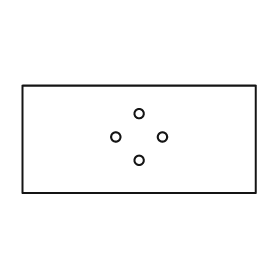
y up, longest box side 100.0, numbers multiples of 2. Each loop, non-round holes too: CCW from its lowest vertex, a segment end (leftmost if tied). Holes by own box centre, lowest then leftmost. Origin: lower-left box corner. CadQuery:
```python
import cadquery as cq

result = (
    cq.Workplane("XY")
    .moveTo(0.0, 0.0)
    .lineTo(100.0, 0.0)
    .lineTo(100.0, 46.0)
    .lineTo(0.0, 46.0)
    .close()
    .moveTo(50.0, 14.0)
    .circle(2.0)
    .moveTo(40.0, 24.0)
    .circle(2.0)
    .moveTo(60.0, 24.0)
    .circle(2.0)
    .moveTo(50.0, 34.0)
    .circle(2.0)
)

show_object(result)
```